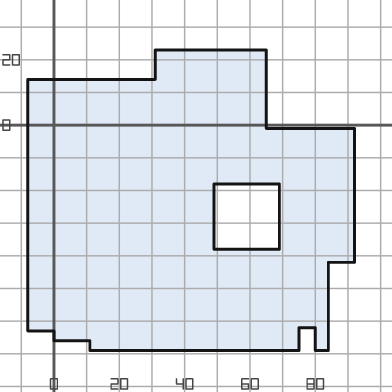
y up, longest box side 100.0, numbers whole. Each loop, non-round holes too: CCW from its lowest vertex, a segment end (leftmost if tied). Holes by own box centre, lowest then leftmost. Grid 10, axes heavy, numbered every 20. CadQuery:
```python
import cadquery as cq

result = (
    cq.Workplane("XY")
    .moveTo(11.0, -69.0)
    .lineTo(75.0, -69.0)
    .lineTo(75.0, -62.0)
    .lineTo(80.0, -62.0)
    .lineTo(80.0, -69.0)
    .lineTo(84.0, -69.0)
    .lineTo(84.0, -42.0)
    .lineTo(92.0, -42.0)
    .lineTo(92.0, -1.0)
    .lineTo(65.0, -1.0)
    .lineTo(65.0, 23.0)
    .lineTo(31.0, 23.0)
    .lineTo(31.0, 14.0)
    .lineTo(-8.0, 14.0)
    .lineTo(-8.0, -63.0)
    .lineTo(0.0, -63.0)
    .lineTo(0.0, -66.0)
    .lineTo(11.0, -66.0)
    .close()
    .moveTo(49.0, -38.0)
    .lineTo(69.0, -38.0)
    .lineTo(69.0, -18.0)
    .lineTo(49.0, -18.0)
    .close()
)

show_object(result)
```